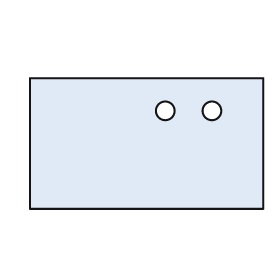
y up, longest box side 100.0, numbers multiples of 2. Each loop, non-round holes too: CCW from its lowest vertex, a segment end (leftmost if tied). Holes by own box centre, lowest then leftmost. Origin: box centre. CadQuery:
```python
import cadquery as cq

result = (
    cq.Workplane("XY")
    .moveTo(-50.0, -28.0)
    .lineTo(50.0, -28.0)
    .lineTo(50.0, 28.0)
    .lineTo(-50.0, 28.0)
    .close()
    .moveTo(8.0, 14.0)
    .circle(4.0)
    .moveTo(28.0, 14.0)
    .circle(4.0)
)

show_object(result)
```